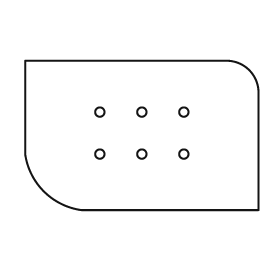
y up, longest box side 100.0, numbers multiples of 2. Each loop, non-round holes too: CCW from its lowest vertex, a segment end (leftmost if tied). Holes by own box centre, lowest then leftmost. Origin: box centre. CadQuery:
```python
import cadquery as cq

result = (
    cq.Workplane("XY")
    .moveTo(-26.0, -32.0)
    .lineTo(50.0, -32.0)
    .lineTo(50.0, 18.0)
    .threePointArc((46.0, 28.0), (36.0, 32.0))
    .lineTo(-50.0, 32.0)
    .lineTo(-50.0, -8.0)
    .threePointArc((-42.0, -24.0), (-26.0, -32.0))
    .close()
    .moveTo(-18.0, -8.0)
    .circle(2.0)
    .moveTo(0.0, -8.0)
    .circle(2.0)
    .moveTo(18.0, -8.0)
    .circle(2.0)
    .moveTo(-18.0, 10.0)
    .circle(2.0)
    .moveTo(0.0, 10.0)
    .circle(2.0)
    .moveTo(18.0, 10.0)
    .circle(2.0)
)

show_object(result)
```